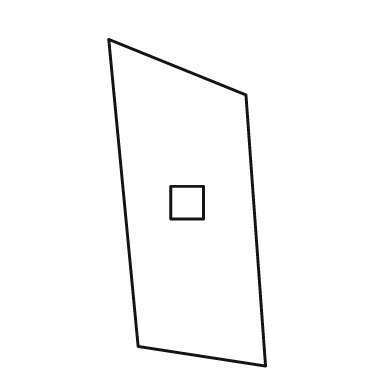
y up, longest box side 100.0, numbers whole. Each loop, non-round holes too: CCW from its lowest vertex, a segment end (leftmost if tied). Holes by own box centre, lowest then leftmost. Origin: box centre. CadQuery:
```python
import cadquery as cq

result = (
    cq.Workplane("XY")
    .moveTo(24.0, -50.0)
    .lineTo(18.0, 33.0)
    .lineTo(-24.0, 50.0)
    .lineTo(-15.0, -44.0)
    .close()
    .moveTo(-5.0, -5.0)
    .lineTo(5.0, -5.0)
    .lineTo(5.0, 5.0)
    .lineTo(-5.0, 5.0)
    .close()
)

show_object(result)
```